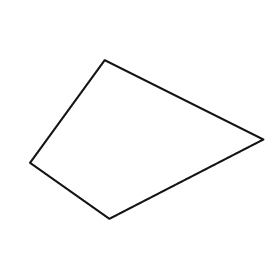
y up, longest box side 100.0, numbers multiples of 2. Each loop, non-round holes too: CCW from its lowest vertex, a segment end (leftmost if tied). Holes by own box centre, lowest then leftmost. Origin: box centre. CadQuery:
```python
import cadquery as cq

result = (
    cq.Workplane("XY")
    .moveTo(-16.0, -34.0)
    .lineTo(50.0, 0.0)
    .lineTo(-18.0, 34.0)
    .lineTo(-50.0, -10.0)
    .close()
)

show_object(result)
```